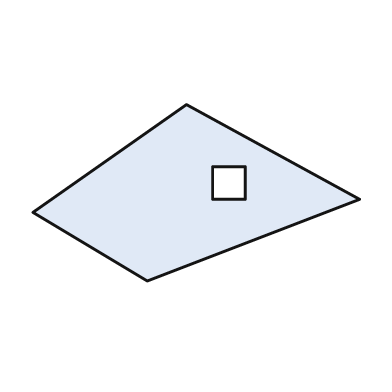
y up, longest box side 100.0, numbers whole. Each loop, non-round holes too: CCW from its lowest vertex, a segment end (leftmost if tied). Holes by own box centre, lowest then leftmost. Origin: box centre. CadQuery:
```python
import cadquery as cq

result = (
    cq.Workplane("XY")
    .moveTo(-15.0, -27.0)
    .lineTo(50.0, -2.0)
    .lineTo(-3.0, 27.0)
    .lineTo(-50.0, -6.0)
    .close()
    .moveTo(5.0, -2.0)
    .lineTo(15.0, -2.0)
    .lineTo(15.0, 8.0)
    .lineTo(5.0, 8.0)
    .close()
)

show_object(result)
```